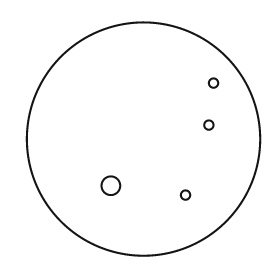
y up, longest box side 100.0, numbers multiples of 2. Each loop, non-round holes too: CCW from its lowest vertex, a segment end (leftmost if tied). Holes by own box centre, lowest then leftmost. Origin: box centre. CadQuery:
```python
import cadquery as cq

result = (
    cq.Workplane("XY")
    .moveTo(0.0, 0.0)
    .circle(50.0)
    .moveTo(18.0, -24.0)
    .circle(2.0)
    .moveTo(-14.0, -20.0)
    .circle(4.0)
    .moveTo(28.0, 6.0)
    .circle(2.0)
    .moveTo(30.0, 24.0)
    .circle(2.0)
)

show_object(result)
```